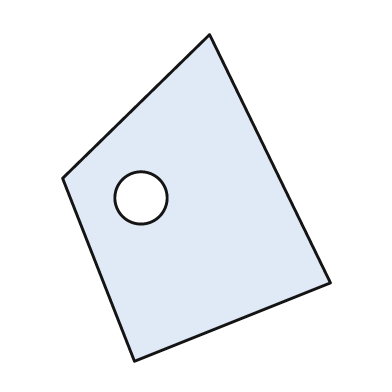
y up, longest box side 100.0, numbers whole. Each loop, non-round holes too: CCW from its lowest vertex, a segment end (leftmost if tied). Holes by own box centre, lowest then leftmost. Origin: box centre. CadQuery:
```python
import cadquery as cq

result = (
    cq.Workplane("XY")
    .moveTo(-19.0, -50.0)
    .lineTo(41.0, -26.0)
    .lineTo(4.0, 50.0)
    .lineTo(-41.0, 6.0)
    .close()
    .moveTo(-17.0, 0.0)
    .circle(8.0)
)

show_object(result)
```